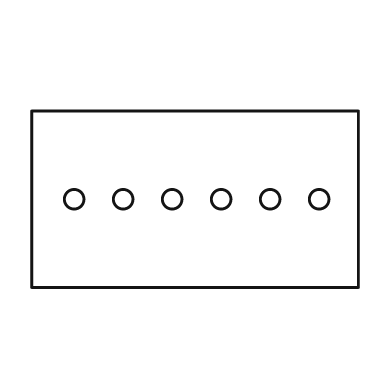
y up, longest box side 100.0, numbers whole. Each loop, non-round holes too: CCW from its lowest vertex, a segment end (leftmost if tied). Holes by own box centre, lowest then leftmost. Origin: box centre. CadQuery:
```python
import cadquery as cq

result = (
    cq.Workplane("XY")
    .moveTo(-50.0, -27.0)
    .lineTo(50.0, -27.0)
    .lineTo(50.0, 27.0)
    .lineTo(-50.0, 27.0)
    .close()
    .moveTo(-37.0, 0.0)
    .circle(3.0)
    .moveTo(-22.0, 0.0)
    .circle(3.0)
    .moveTo(-7.0, 0.0)
    .circle(3.0)
    .moveTo(8.0, 0.0)
    .circle(3.0)
    .moveTo(23.0, 0.0)
    .circle(3.0)
    .moveTo(38.0, 0.0)
    .circle(3.0)
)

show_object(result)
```